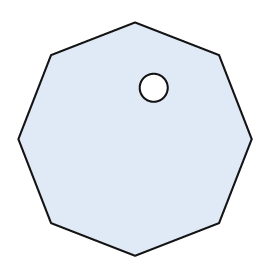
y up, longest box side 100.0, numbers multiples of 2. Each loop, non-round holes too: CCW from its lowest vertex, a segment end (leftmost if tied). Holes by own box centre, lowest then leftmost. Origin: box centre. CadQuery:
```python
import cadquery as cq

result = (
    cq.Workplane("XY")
    .moveTo(0.0, -50.0)
    .lineTo(36.0, -36.0)
    .lineTo(50.0, 0.0)
    .lineTo(36.0, 36.0)
    .lineTo(0.0, 50.0)
    .lineTo(-36.0, 36.0)
    .lineTo(-50.0, 0.0)
    .lineTo(-36.0, -36.0)
    .close()
    .moveTo(8.0, 22.0)
    .circle(6.0)
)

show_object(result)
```